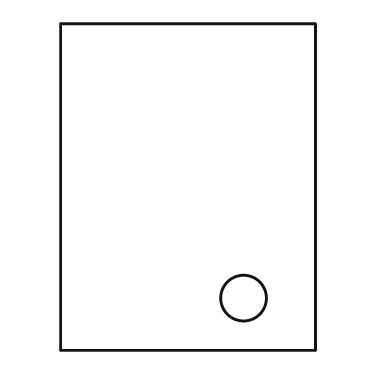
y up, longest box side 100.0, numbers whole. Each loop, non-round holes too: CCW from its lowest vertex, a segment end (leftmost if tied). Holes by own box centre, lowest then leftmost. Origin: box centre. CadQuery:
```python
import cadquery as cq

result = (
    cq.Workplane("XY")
    .moveTo(-39.0, -50.0)
    .lineTo(39.0, -50.0)
    .lineTo(39.0, 50.0)
    .lineTo(-39.0, 50.0)
    .close()
    .moveTo(17.0, -34.0)
    .circle(7.0)
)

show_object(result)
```